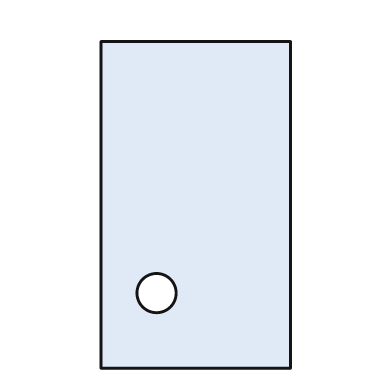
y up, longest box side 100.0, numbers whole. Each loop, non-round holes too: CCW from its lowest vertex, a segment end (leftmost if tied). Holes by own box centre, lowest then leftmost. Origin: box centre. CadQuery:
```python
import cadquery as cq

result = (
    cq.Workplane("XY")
    .moveTo(-29.0, -50.0)
    .lineTo(29.0, -50.0)
    .lineTo(29.0, 50.0)
    .lineTo(-29.0, 50.0)
    .close()
    .moveTo(-12.0, -27.0)
    .circle(6.0)
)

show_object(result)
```